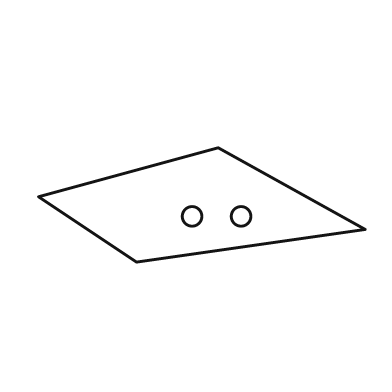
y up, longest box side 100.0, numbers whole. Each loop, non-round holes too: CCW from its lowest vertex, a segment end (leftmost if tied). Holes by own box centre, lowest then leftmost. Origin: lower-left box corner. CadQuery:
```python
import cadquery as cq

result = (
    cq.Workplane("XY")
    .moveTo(30.0, 0.0)
    .lineTo(100.0, 10.0)
    .lineTo(55.0, 35.0)
    .lineTo(0.0, 20.0)
    .close()
    .moveTo(47.0, 14.0)
    .circle(3.0)
    .moveTo(62.0, 14.0)
    .circle(3.0)
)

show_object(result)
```